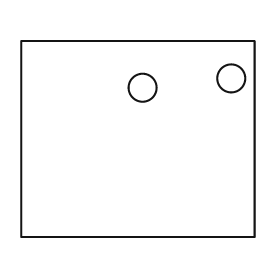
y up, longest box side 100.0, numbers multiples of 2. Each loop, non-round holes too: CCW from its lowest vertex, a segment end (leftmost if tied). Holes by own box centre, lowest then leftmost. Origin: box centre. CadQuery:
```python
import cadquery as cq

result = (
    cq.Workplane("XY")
    .moveTo(-50.0, -42.0)
    .lineTo(50.0, -42.0)
    .lineTo(50.0, 42.0)
    .lineTo(-50.0, 42.0)
    .close()
    .moveTo(2.0, 22.0)
    .circle(6.0)
    .moveTo(40.0, 26.0)
    .circle(6.0)
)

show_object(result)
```